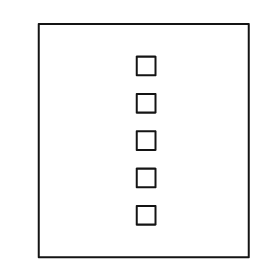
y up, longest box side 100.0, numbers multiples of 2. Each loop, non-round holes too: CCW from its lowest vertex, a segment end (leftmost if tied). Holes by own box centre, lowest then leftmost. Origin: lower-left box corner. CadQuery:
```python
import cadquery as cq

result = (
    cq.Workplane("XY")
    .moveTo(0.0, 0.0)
    .lineTo(90.0, 0.0)
    .lineTo(90.0, 100.0)
    .lineTo(0.0, 100.0)
    .close()
    .moveTo(42.0, 14.0)
    .lineTo(50.0, 14.0)
    .lineTo(50.0, 22.0)
    .lineTo(42.0, 22.0)
    .close()
    .moveTo(42.0, 30.0)
    .lineTo(50.0, 30.0)
    .lineTo(50.0, 38.0)
    .lineTo(42.0, 38.0)
    .close()
    .moveTo(42.0, 46.0)
    .lineTo(50.0, 46.0)
    .lineTo(50.0, 54.0)
    .lineTo(42.0, 54.0)
    .close()
    .moveTo(42.0, 62.0)
    .lineTo(50.0, 62.0)
    .lineTo(50.0, 70.0)
    .lineTo(42.0, 70.0)
    .close()
    .moveTo(42.0, 78.0)
    .lineTo(50.0, 78.0)
    .lineTo(50.0, 86.0)
    .lineTo(42.0, 86.0)
    .close()
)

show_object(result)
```